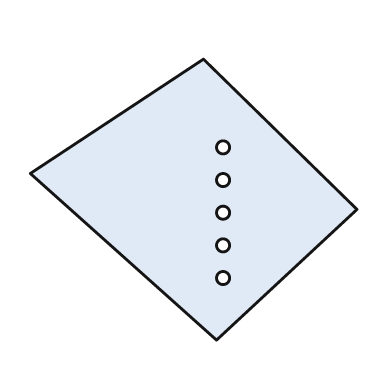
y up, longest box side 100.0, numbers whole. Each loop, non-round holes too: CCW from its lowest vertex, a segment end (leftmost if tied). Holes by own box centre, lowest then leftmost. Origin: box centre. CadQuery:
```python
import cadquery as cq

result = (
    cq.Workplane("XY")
    .moveTo(7.0, -43.0)
    .lineTo(50.0, -3.0)
    .lineTo(3.0, 43.0)
    .lineTo(-50.0, 8.0)
    .close()
    .moveTo(9.0, -24.0)
    .circle(2.0)
    .moveTo(9.0, -14.0)
    .circle(2.0)
    .moveTo(9.0, -4.0)
    .circle(2.0)
    .moveTo(9.0, 6.0)
    .circle(2.0)
    .moveTo(9.0, 16.0)
    .circle(2.0)
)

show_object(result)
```